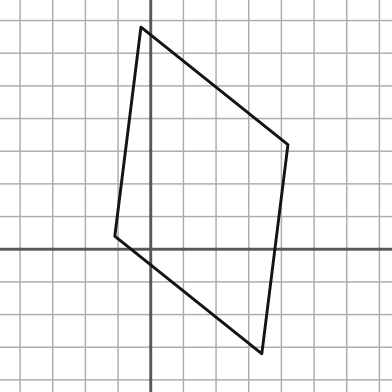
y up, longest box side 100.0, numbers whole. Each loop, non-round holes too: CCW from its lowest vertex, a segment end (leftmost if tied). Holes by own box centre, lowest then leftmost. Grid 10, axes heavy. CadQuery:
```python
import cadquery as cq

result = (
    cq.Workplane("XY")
    .moveTo(34.0, -32.0)
    .lineTo(42.0, 32.0)
    .lineTo(-3.0, 68.0)
    .lineTo(-11.0, 4.0)
    .close()
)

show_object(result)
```